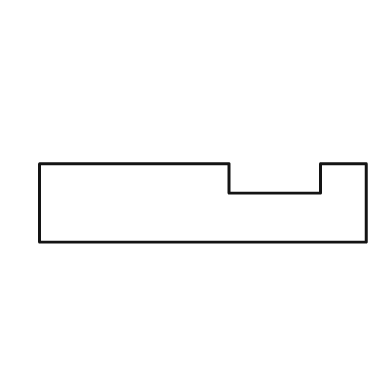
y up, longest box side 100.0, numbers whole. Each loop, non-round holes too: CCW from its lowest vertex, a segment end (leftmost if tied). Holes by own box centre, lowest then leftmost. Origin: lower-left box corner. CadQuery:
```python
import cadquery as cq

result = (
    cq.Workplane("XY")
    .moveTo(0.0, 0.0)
    .lineTo(100.0, 0.0)
    .lineTo(100.0, 24.0)
    .lineTo(86.0, 24.0)
    .lineTo(86.0, 15.0)
    .lineTo(58.0, 15.0)
    .lineTo(58.0, 24.0)
    .lineTo(0.0, 24.0)
    .close()
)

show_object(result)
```